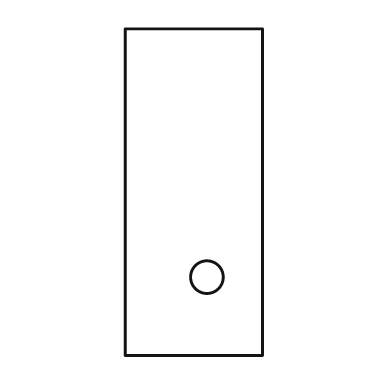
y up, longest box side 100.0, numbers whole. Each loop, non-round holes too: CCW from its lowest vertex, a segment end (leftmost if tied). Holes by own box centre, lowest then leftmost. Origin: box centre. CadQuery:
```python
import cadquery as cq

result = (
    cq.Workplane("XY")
    .moveTo(-21.0, -50.0)
    .lineTo(21.0, -50.0)
    .lineTo(21.0, 50.0)
    .lineTo(-21.0, 50.0)
    .close()
    .moveTo(4.0, -26.0)
    .circle(5.0)
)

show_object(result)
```